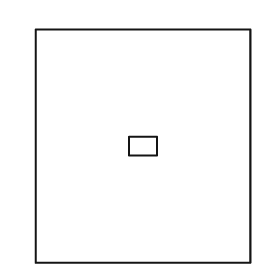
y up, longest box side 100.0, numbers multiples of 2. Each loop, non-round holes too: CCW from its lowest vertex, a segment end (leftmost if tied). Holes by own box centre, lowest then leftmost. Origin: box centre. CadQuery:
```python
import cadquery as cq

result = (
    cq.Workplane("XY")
    .moveTo(-46.0, -50.0)
    .lineTo(46.0, -50.0)
    .lineTo(46.0, 50.0)
    .lineTo(-46.0, 50.0)
    .close()
    .moveTo(-6.0, -4.0)
    .lineTo(6.0, -4.0)
    .lineTo(6.0, 4.0)
    .lineTo(-6.0, 4.0)
    .close()
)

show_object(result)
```